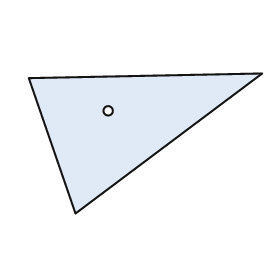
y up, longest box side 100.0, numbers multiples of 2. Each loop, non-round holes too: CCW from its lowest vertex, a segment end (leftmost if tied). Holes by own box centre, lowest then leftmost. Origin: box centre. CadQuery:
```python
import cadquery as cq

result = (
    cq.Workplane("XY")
    .moveTo(-30.0, -30.0)
    .lineTo(50.0, 30.0)
    .lineTo(-50.0, 28.0)
    .close()
    .moveTo(-16.0, 14.0)
    .circle(2.0)
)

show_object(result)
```